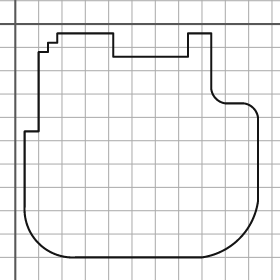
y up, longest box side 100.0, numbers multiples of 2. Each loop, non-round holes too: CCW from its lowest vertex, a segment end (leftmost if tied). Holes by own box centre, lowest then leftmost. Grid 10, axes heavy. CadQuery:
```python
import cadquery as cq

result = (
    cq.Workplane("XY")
    .moveTo(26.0, -100.0)
    .lineTo(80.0, -100.0)
    .threePointArc((96.0, -92.0), (104.0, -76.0))
    .lineTo(104.0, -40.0)
    .threePointArc((102.0, -36.0), (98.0, -34.0))
    .lineTo(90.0, -34.0)
    .threePointArc((86.0, -32.0), (84.0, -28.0))
    .lineTo(84.0, -4.0)
    .lineTo(74.0, -4.0)
    .lineTo(74.0, -14.0)
    .lineTo(42.0, -14.0)
    .lineTo(42.0, -4.0)
    .lineTo(18.0, -4.0)
    .lineTo(18.0, -8.0)
    .lineTo(14.0, -8.0)
    .lineTo(14.0, -12.0)
    .lineTo(10.0, -12.0)
    .lineTo(10.0, -46.0)
    .lineTo(4.0, -46.0)
    .lineTo(4.0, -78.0)
    .threePointArc((10.0, -94.0), (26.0, -100.0))
    .close()
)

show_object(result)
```